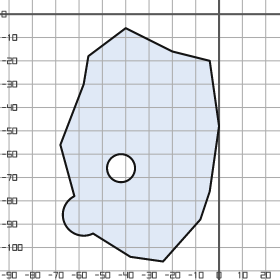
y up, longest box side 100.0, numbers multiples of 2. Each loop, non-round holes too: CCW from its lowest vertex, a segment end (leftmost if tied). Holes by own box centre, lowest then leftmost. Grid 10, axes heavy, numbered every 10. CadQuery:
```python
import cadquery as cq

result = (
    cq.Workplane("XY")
    .moveTo(-24.0, -106.0)
    .lineTo(-8.0, -88.0)
    .lineTo(-4.0, -76.0)
    .lineTo(0.0, -48.0)
    .lineTo(-4.0, -20.0)
    .lineTo(-20.0, -16.0)
    .lineTo(-40.0, -6.0)
    .lineTo(-56.0, -18.0)
    .lineTo(-58.0, -30.0)
    .lineTo(-68.0, -56.0)
    .lineTo(-62.0, -78.0)
    .threePointArc((-66.0, -90.0), (-54.0, -94.0))
    .lineTo(-38.0, -104.0)
    .close()
    .moveTo(-42.0, -66.0)
    .circle(6.0)
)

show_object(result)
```